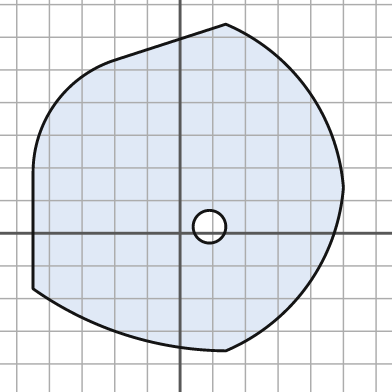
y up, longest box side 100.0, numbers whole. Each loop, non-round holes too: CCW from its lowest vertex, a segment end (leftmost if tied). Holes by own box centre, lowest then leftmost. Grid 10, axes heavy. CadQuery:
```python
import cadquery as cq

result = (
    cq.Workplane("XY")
    .moveTo(14.0, -36.0)
    .threePointArc((39.0, -16.0), (50.0, 14.0))
    .threePointArc((39.0, 44.0), (14.0, 64.0))
    .lineTo(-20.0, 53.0)
    .threePointArc((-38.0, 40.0), (-45.0, 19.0))
    .lineTo(-45.0, -17.0)
    .threePointArc((-17.0, -31.0), (14.0, -36.0))
    .close()
    .moveTo(9.0, 2.0)
    .circle(5.0)
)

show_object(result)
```